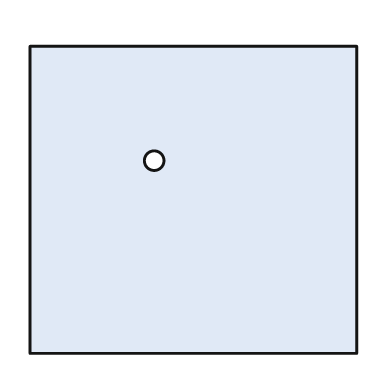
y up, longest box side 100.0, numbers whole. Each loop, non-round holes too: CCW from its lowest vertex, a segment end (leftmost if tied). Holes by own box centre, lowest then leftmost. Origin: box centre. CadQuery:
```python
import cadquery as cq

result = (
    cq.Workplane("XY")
    .moveTo(-50.0, -47.0)
    .lineTo(50.0, -47.0)
    .lineTo(50.0, 47.0)
    .lineTo(-50.0, 47.0)
    .close()
    .moveTo(-12.0, 12.0)
    .circle(3.0)
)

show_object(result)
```